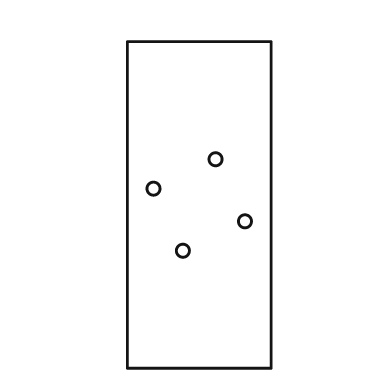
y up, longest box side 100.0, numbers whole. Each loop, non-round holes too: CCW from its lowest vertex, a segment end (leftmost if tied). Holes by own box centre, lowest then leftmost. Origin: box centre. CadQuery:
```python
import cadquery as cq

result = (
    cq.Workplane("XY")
    .moveTo(-22.0, -50.0)
    .lineTo(22.0, -50.0)
    .lineTo(22.0, 50.0)
    .lineTo(-22.0, 50.0)
    .close()
    .moveTo(-5.0, -14.0)
    .circle(2.0)
    .moveTo(14.0, -5.0)
    .circle(2.0)
    .moveTo(-14.0, 5.0)
    .circle(2.0)
    .moveTo(5.0, 14.0)
    .circle(2.0)
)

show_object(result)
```